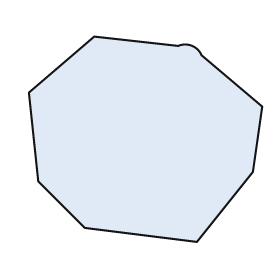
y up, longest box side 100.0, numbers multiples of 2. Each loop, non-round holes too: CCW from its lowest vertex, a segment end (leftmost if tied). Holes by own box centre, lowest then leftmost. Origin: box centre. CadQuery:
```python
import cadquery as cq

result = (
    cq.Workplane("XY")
    .moveTo(22.0, -44.0)
    .lineTo(46.0, -14.0)
    .lineTo(50.0, 14.0)
    .lineTo(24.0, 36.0)
    .threePointArc((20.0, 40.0), (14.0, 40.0))
    .lineTo(-22.0, 44.0)
    .lineTo(-50.0, 20.0)
    .lineTo(-46.0, -18.0)
    .lineTo(-26.0, -38.0)
    .close()
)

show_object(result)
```